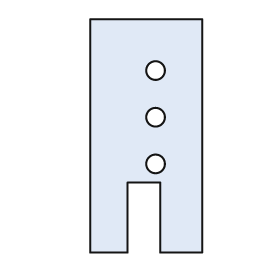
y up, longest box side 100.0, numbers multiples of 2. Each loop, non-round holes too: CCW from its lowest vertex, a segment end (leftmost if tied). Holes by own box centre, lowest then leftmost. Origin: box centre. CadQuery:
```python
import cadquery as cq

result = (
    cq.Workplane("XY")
    .moveTo(-24.0, -50.0)
    .lineTo(-8.0, -50.0)
    .lineTo(-8.0, -20.0)
    .lineTo(6.0, -20.0)
    .lineTo(6.0, -50.0)
    .lineTo(24.0, -50.0)
    .lineTo(24.0, 50.0)
    .lineTo(-24.0, 50.0)
    .close()
    .moveTo(4.0, -12.0)
    .circle(4.0)
    .moveTo(4.0, 8.0)
    .circle(4.0)
    .moveTo(4.0, 28.0)
    .circle(4.0)
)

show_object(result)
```